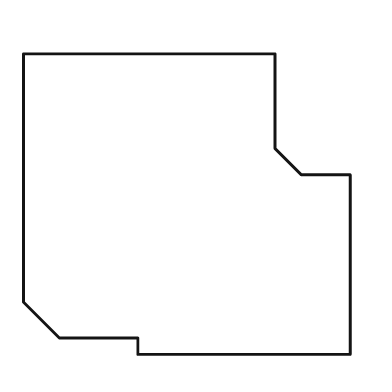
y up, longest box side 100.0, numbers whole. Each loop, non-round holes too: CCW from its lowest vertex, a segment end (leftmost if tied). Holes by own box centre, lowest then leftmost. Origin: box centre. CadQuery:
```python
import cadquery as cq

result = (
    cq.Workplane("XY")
    .moveTo(-15.0, -46.0)
    .lineTo(50.0, -46.0)
    .lineTo(50.0, 9.0)
    .lineTo(35.0, 9.0)
    .lineTo(27.0, 17.0)
    .lineTo(27.0, 46.0)
    .lineTo(-50.0, 46.0)
    .lineTo(-50.0, -30.0)
    .lineTo(-39.0, -41.0)
    .lineTo(-15.0, -41.0)
    .close()
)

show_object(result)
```